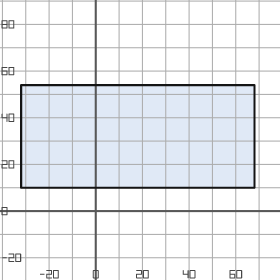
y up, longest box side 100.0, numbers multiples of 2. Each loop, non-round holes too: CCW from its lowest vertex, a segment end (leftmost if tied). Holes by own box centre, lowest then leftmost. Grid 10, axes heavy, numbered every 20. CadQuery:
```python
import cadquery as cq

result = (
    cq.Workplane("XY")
    .moveTo(-32.0, 10.0)
    .lineTo(68.0, 10.0)
    .lineTo(68.0, 54.0)
    .lineTo(-32.0, 54.0)
    .close()
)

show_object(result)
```